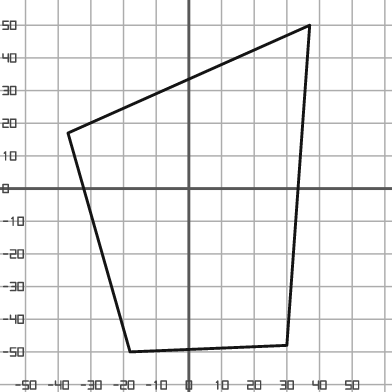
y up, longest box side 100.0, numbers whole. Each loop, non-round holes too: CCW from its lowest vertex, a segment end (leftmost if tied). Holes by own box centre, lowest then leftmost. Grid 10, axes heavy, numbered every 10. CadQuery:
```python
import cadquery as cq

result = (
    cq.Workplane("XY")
    .moveTo(-18.0, -50.0)
    .lineTo(30.0, -48.0)
    .lineTo(37.0, 50.0)
    .lineTo(-37.0, 17.0)
    .close()
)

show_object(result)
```